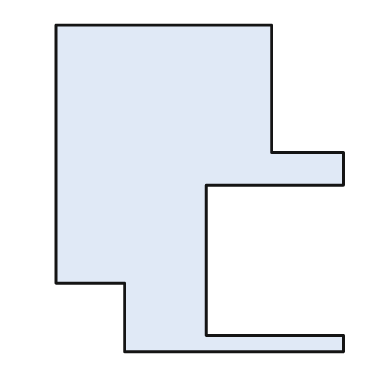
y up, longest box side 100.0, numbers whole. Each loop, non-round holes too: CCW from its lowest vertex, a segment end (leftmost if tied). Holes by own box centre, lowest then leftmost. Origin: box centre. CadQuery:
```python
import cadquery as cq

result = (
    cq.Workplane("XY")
    .moveTo(-23.0, -50.0)
    .lineTo(44.0, -50.0)
    .lineTo(44.0, -45.0)
    .lineTo(2.0, -45.0)
    .lineTo(2.0, 1.0)
    .lineTo(44.0, 1.0)
    .lineTo(44.0, 11.0)
    .lineTo(22.0, 11.0)
    .lineTo(22.0, 50.0)
    .lineTo(-44.0, 50.0)
    .lineTo(-44.0, -29.0)
    .lineTo(-23.0, -29.0)
    .close()
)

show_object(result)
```